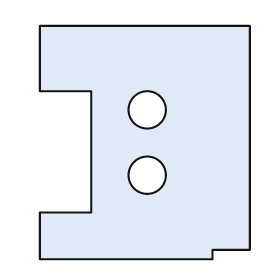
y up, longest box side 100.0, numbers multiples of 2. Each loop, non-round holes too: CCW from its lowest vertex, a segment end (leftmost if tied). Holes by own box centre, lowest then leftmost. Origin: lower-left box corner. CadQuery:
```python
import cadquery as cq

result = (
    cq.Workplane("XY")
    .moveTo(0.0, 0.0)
    .lineTo(74.0, 0.0)
    .lineTo(74.0, 4.0)
    .lineTo(90.0, 4.0)
    .lineTo(90.0, 100.0)
    .lineTo(0.0, 100.0)
    .lineTo(0.0, 72.0)
    .lineTo(22.0, 72.0)
    .lineTo(22.0, 20.0)
    .lineTo(0.0, 20.0)
    .close()
    .moveTo(46.0, 36.0)
    .circle(8.0)
    .moveTo(46.0, 64.0)
    .circle(8.0)
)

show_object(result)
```